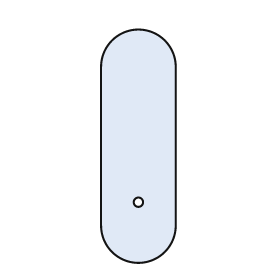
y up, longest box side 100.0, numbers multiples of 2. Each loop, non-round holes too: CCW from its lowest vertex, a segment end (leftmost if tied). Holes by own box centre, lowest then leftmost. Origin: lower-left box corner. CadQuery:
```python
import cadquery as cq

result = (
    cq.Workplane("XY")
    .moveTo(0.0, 16.0)
    .threePointArc((16.0, 0.0), (32.0, 16.0))
    .lineTo(32.0, 84.0)
    .threePointArc((16.0, 100.0), (0.0, 84.0))
    .close()
    .moveTo(16.0, 26.0)
    .circle(2.0)
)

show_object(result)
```